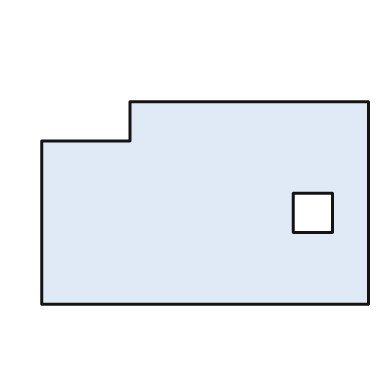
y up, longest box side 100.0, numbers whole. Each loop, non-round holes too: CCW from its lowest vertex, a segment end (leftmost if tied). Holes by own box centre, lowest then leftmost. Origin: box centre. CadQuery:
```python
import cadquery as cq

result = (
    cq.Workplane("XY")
    .moveTo(-50.0, -31.0)
    .lineTo(50.0, -31.0)
    .lineTo(50.0, 31.0)
    .lineTo(-23.0, 31.0)
    .lineTo(-23.0, 19.0)
    .lineTo(-50.0, 19.0)
    .close()
    .moveTo(27.0, -9.0)
    .lineTo(39.0, -9.0)
    .lineTo(39.0, 3.0)
    .lineTo(27.0, 3.0)
    .close()
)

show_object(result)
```